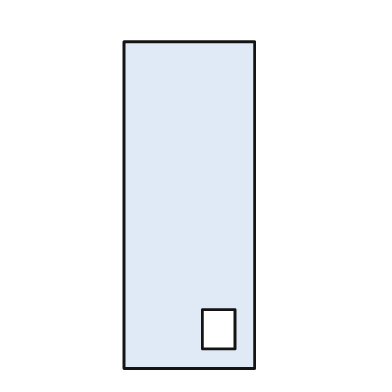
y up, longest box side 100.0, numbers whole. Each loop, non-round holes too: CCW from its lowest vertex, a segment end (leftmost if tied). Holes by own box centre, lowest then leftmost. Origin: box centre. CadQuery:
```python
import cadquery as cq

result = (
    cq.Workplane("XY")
    .moveTo(-20.0, -50.0)
    .lineTo(20.0, -50.0)
    .lineTo(20.0, 50.0)
    .lineTo(-20.0, 50.0)
    .close()
    .moveTo(4.0, -44.0)
    .lineTo(14.0, -44.0)
    .lineTo(14.0, -32.0)
    .lineTo(4.0, -32.0)
    .close()
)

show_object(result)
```